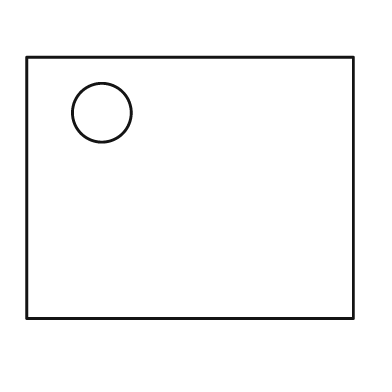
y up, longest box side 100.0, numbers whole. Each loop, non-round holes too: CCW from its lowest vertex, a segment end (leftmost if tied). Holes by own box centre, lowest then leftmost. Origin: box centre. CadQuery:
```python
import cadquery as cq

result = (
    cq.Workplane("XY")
    .moveTo(-50.0, -40.0)
    .lineTo(50.0, -40.0)
    .lineTo(50.0, 40.0)
    .lineTo(-50.0, 40.0)
    .close()
    .moveTo(-27.0, 23.0)
    .circle(9.0)
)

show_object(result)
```